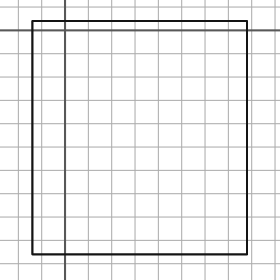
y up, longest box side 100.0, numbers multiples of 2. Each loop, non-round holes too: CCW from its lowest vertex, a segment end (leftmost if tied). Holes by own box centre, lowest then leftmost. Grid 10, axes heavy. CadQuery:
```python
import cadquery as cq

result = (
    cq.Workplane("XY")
    .moveTo(-14.0, -96.0)
    .lineTo(78.0, -96.0)
    .lineTo(78.0, 4.0)
    .lineTo(-14.0, 4.0)
    .close()
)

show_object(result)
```